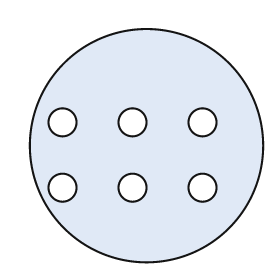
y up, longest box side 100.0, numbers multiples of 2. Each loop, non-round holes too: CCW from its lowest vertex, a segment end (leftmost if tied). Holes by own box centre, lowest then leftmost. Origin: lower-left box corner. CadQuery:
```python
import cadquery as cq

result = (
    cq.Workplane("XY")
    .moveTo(50.0, 50.0)
    .circle(50.0)
    .moveTo(14.0, 32.0)
    .circle(6.0)
    .moveTo(44.0, 32.0)
    .circle(6.0)
    .moveTo(74.0, 32.0)
    .circle(6.0)
    .moveTo(14.0, 60.0)
    .circle(6.0)
    .moveTo(44.0, 60.0)
    .circle(6.0)
    .moveTo(74.0, 60.0)
    .circle(6.0)
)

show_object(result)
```